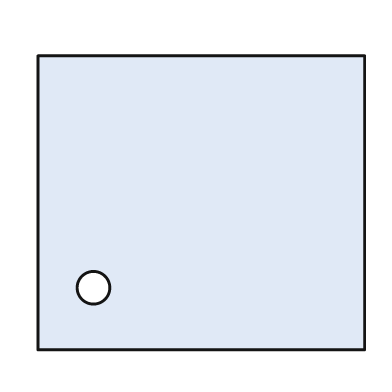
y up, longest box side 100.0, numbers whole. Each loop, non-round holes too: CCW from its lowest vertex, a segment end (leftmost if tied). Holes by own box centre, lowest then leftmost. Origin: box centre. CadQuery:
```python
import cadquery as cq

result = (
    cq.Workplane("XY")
    .moveTo(-50.0, -45.0)
    .lineTo(50.0, -45.0)
    .lineTo(50.0, 45.0)
    .lineTo(-50.0, 45.0)
    .close()
    .moveTo(-33.0, -26.0)
    .circle(5.0)
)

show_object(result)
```